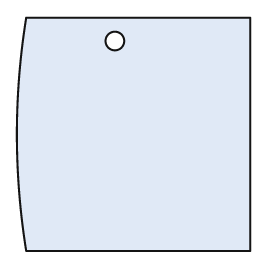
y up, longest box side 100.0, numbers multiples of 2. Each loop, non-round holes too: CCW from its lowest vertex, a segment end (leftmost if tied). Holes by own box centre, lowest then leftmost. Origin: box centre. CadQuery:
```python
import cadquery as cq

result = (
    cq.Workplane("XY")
    .moveTo(-46.0, -50.0)
    .lineTo(50.0, -50.0)
    .lineTo(50.0, 50.0)
    .lineTo(-46.0, 50.0)
    .threePointArc((-50.0, 0.0), (-46.0, -50.0))
    .close()
    .moveTo(-8.0, 40.0)
    .circle(4.0)
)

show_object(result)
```